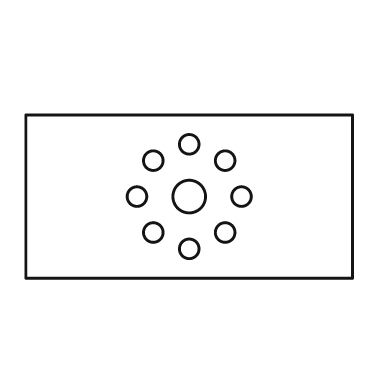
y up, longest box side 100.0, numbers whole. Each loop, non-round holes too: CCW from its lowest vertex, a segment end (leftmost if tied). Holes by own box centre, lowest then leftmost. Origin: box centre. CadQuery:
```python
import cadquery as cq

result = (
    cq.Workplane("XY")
    .moveTo(-50.0, -25.0)
    .lineTo(50.0, -25.0)
    .lineTo(50.0, 25.0)
    .lineTo(-50.0, 25.0)
    .close()
    .moveTo(0.0, -16.0)
    .circle(3.0)
    .moveTo(-11.0, -11.0)
    .circle(3.0)
    .moveTo(11.0, -11.0)
    .circle(3.0)
    .moveTo(-16.0, 0.0)
    .circle(3.0)
    .moveTo(0.0, 0.0)
    .circle(5.0)
    .moveTo(16.0, 0.0)
    .circle(3.0)
    .moveTo(-11.0, 11.0)
    .circle(3.0)
    .moveTo(11.0, 11.0)
    .circle(3.0)
    .moveTo(0.0, 16.0)
    .circle(3.0)
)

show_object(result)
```